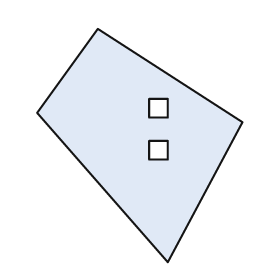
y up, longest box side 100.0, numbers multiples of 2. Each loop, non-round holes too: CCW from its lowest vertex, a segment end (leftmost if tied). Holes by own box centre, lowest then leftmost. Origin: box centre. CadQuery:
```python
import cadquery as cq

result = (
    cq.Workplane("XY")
    .moveTo(12.0, -50.0)
    .lineTo(44.0, 10.0)
    .lineTo(-18.0, 50.0)
    .lineTo(-44.0, 14.0)
    .close()
    .moveTo(4.0, -6.0)
    .lineTo(12.0, -6.0)
    .lineTo(12.0, 2.0)
    .lineTo(4.0, 2.0)
    .close()
    .moveTo(4.0, 12.0)
    .lineTo(12.0, 12.0)
    .lineTo(12.0, 20.0)
    .lineTo(4.0, 20.0)
    .close()
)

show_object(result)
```